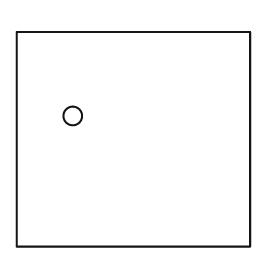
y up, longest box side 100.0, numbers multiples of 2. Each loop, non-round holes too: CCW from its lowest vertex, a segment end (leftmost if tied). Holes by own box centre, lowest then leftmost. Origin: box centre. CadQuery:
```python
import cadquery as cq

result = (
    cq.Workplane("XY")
    .moveTo(-50.0, -46.0)
    .lineTo(50.0, -46.0)
    .lineTo(50.0, 46.0)
    .lineTo(-50.0, 46.0)
    .close()
    .moveTo(-26.0, 10.0)
    .circle(4.0)
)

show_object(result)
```